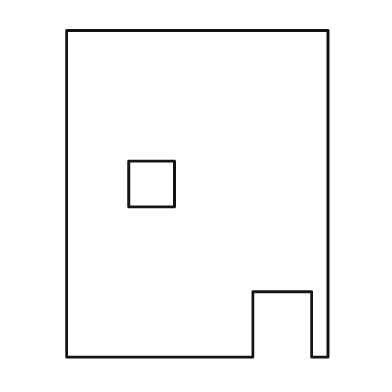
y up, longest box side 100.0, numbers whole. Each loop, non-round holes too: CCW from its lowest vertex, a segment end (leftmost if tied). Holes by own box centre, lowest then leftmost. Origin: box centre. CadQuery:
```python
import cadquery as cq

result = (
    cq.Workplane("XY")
    .moveTo(-40.0, -50.0)
    .lineTo(17.0, -50.0)
    .lineTo(17.0, -30.0)
    .lineTo(35.0, -30.0)
    .lineTo(35.0, -50.0)
    .lineTo(40.0, -50.0)
    .lineTo(40.0, 50.0)
    .lineTo(-40.0, 50.0)
    .close()
    .moveTo(-21.0, -4.0)
    .lineTo(-7.0, -4.0)
    .lineTo(-7.0, 10.0)
    .lineTo(-21.0, 10.0)
    .close()
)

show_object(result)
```